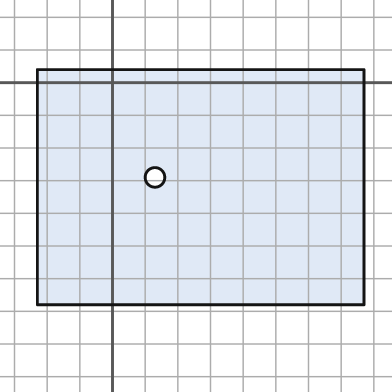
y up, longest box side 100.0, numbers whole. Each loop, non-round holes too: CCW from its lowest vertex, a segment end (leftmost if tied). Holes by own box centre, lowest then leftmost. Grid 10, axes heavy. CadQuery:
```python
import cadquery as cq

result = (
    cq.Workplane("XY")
    .moveTo(-23.0, -68.0)
    .lineTo(77.0, -68.0)
    .lineTo(77.0, 4.0)
    .lineTo(-23.0, 4.0)
    .close()
    .moveTo(13.0, -29.0)
    .circle(3.0)
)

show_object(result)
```